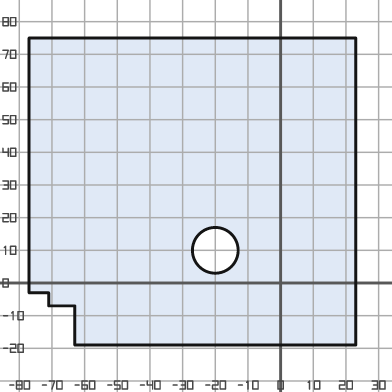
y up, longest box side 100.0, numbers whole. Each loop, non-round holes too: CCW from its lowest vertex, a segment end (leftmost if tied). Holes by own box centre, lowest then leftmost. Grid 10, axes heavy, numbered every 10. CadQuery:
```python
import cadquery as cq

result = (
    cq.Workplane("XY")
    .moveTo(-63.0, -19.0)
    .lineTo(23.0, -19.0)
    .lineTo(23.0, 75.0)
    .lineTo(-77.0, 75.0)
    .lineTo(-77.0, -3.0)
    .lineTo(-71.0, -3.0)
    .lineTo(-71.0, -7.0)
    .lineTo(-63.0, -7.0)
    .close()
    .moveTo(-20.0, 10.0)
    .circle(7.0)
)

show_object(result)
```